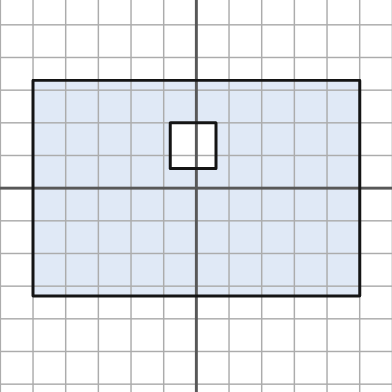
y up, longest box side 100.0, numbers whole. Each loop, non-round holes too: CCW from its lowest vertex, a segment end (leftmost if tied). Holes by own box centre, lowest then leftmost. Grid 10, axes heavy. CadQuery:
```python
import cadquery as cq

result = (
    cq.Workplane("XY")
    .moveTo(-50.0, -33.0)
    .lineTo(50.0, -33.0)
    .lineTo(50.0, 33.0)
    .lineTo(-50.0, 33.0)
    .close()
    .moveTo(-8.0, 6.0)
    .lineTo(6.0, 6.0)
    .lineTo(6.0, 20.0)
    .lineTo(-8.0, 20.0)
    .close()
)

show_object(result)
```